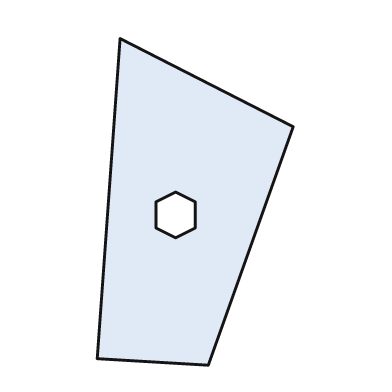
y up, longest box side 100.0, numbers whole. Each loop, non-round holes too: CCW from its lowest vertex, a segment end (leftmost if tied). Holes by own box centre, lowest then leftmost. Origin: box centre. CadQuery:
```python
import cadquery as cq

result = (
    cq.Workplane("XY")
    .moveTo(4.0, -50.0)
    .lineTo(30.0, 23.0)
    .lineTo(-23.0, 50.0)
    .lineTo(-30.0, -48.0)
    .close()
    .moveTo(-6.0, -11.0)
    .lineTo(0.0, -8.0)
    .lineTo(0.0, 0.0)
    .lineTo(-6.0, 3.0)
    .lineTo(-12.0, 0.0)
    .lineTo(-12.0, -8.0)
    .close()
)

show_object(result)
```